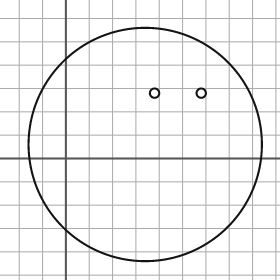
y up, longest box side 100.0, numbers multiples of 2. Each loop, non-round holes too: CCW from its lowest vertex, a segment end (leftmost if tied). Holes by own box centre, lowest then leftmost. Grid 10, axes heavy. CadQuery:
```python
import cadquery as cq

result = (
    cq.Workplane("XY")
    .moveTo(34.0, 6.0)
    .circle(50.0)
    .moveTo(38.0, 28.0)
    .circle(2.0)
    .moveTo(58.0, 28.0)
    .circle(2.0)
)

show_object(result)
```